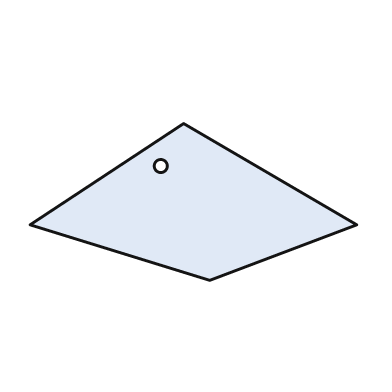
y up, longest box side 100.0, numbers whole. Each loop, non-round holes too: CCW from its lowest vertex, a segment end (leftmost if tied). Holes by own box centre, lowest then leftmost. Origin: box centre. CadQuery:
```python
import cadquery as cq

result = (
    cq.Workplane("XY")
    .moveTo(5.0, -24.0)
    .lineTo(50.0, -7.0)
    .lineTo(-3.0, 24.0)
    .lineTo(-50.0, -7.0)
    .close()
    .moveTo(-10.0, 11.0)
    .circle(2.0)
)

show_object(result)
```